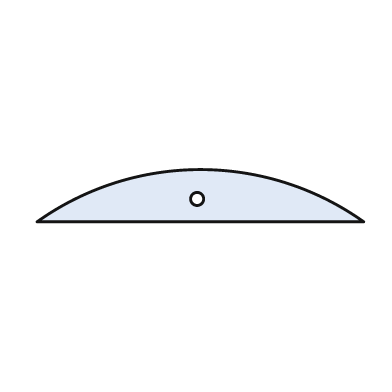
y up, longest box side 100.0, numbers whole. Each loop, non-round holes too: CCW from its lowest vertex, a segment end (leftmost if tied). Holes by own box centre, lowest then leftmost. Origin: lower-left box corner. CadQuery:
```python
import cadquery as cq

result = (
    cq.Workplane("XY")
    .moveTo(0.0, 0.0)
    .lineTo(100.0, 0.0)
    .threePointArc((50.0, 16.0), (0.0, 0.0))
    .close()
    .moveTo(49.0, 7.0)
    .circle(2.0)
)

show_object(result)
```